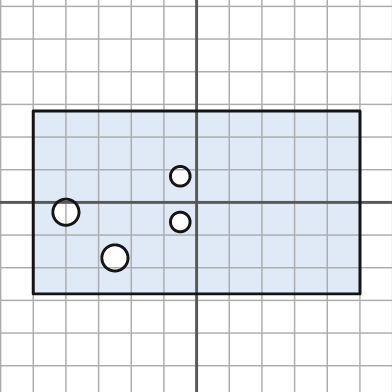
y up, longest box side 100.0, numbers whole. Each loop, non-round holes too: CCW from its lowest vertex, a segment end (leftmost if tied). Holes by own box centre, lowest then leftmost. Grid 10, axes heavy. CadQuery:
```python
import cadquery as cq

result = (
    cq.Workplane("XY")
    .moveTo(-50.0, -28.0)
    .lineTo(50.0, -28.0)
    .lineTo(50.0, 28.0)
    .lineTo(-50.0, 28.0)
    .close()
    .moveTo(-25.0, -17.0)
    .circle(4.0)
    .moveTo(-5.0, -6.0)
    .circle(3.0)
    .moveTo(-40.0, -3.0)
    .circle(4.0)
    .moveTo(-5.0, 8.0)
    .circle(3.0)
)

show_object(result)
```